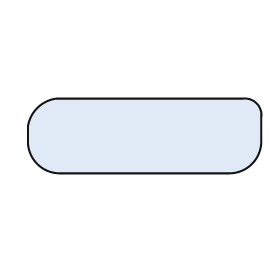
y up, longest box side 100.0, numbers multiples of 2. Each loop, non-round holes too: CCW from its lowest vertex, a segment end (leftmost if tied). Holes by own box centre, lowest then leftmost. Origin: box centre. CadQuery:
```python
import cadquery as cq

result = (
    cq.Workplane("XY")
    .moveTo(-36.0, -16.0)
    .lineTo(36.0, -16.0)
    .threePointArc((46.0, -12.0), (50.0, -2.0))
    .lineTo(50.0, 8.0)
    .threePointArc((48.0, 14.0), (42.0, 16.0))
    .lineTo(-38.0, 16.0)
    .threePointArc((-46.0, 12.0), (-50.0, 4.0))
    .lineTo(-50.0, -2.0)
    .threePointArc((-46.0, -12.0), (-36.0, -16.0))
    .close()
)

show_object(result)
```